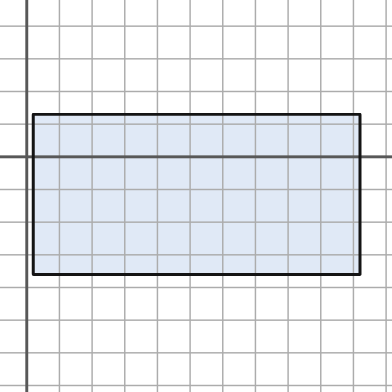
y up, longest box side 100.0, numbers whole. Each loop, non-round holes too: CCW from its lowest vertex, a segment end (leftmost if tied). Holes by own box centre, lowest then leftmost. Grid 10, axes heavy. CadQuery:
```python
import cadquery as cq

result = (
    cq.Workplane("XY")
    .moveTo(2.0, -36.0)
    .lineTo(102.0, -36.0)
    .lineTo(102.0, 13.0)
    .lineTo(2.0, 13.0)
    .close()
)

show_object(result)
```